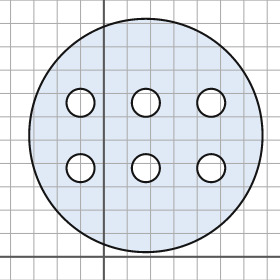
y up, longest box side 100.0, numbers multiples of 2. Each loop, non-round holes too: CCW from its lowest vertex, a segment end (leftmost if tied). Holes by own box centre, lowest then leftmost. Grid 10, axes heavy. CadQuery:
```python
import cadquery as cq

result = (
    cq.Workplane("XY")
    .moveTo(18.0, 52.0)
    .circle(50.0)
    .moveTo(-10.0, 38.0)
    .circle(6.0)
    .moveTo(18.0, 38.0)
    .circle(6.0)
    .moveTo(46.0, 38.0)
    .circle(6.0)
    .moveTo(-10.0, 66.0)
    .circle(6.0)
    .moveTo(18.0, 66.0)
    .circle(6.0)
    .moveTo(46.0, 66.0)
    .circle(6.0)
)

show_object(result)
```